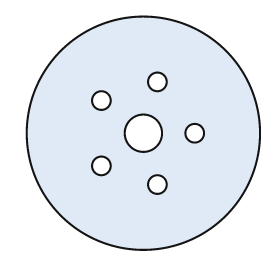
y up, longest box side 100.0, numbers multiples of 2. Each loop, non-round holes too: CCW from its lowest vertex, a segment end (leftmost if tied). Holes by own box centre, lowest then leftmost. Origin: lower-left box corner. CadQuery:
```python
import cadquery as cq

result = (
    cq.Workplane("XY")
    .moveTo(50.0, 50.0)
    .circle(50.0)
    .moveTo(56.0, 28.0)
    .circle(4.0)
    .moveTo(32.0, 36.0)
    .circle(4.0)
    .moveTo(50.0, 50.0)
    .circle(8.0)
    .moveTo(72.0, 50.0)
    .circle(4.0)
    .moveTo(32.0, 64.0)
    .circle(4.0)
    .moveTo(56.0, 72.0)
    .circle(4.0)
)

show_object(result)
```